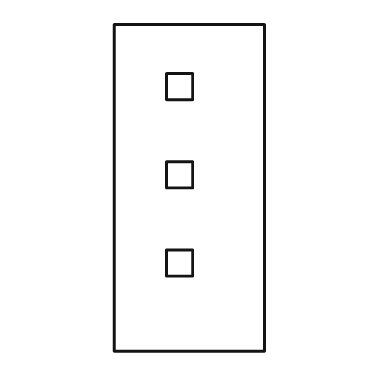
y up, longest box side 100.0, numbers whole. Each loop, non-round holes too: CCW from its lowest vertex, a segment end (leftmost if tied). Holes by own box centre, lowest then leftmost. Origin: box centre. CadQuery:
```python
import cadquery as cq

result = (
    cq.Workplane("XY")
    .moveTo(-23.0, -50.0)
    .lineTo(23.0, -50.0)
    .lineTo(23.0, 50.0)
    .lineTo(-23.0, 50.0)
    .close()
    .moveTo(-7.0, -27.0)
    .lineTo(1.0, -27.0)
    .lineTo(1.0, -19.0)
    .lineTo(-7.0, -19.0)
    .close()
    .moveTo(-7.0, 0.0)
    .lineTo(1.0, 0.0)
    .lineTo(1.0, 8.0)
    .lineTo(-7.0, 8.0)
    .close()
    .moveTo(-7.0, 27.0)
    .lineTo(1.0, 27.0)
    .lineTo(1.0, 35.0)
    .lineTo(-7.0, 35.0)
    .close()
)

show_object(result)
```